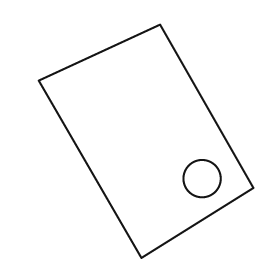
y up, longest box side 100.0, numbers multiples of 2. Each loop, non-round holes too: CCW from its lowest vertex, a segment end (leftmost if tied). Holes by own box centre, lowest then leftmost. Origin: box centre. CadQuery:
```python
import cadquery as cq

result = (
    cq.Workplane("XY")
    .moveTo(-2.0, -50.0)
    .lineTo(46.0, -20.0)
    .lineTo(6.0, 50.0)
    .lineTo(-46.0, 26.0)
    .close()
    .moveTo(24.0, -16.0)
    .circle(8.0)
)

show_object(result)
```